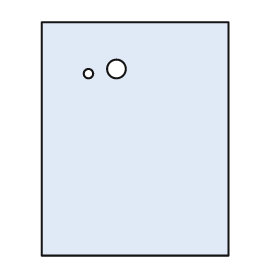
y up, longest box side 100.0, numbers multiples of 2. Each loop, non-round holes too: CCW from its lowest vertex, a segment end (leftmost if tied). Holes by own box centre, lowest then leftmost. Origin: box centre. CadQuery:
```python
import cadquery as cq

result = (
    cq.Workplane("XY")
    .moveTo(-40.0, -50.0)
    .lineTo(40.0, -50.0)
    .lineTo(40.0, 50.0)
    .lineTo(-40.0, 50.0)
    .close()
    .moveTo(-20.0, 28.0)
    .circle(2.0)
    .moveTo(-8.0, 30.0)
    .circle(4.0)
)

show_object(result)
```